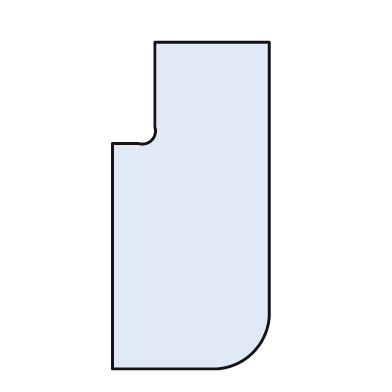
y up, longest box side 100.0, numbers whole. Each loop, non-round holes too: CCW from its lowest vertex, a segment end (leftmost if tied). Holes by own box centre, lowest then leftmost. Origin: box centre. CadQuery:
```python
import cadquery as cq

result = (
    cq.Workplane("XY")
    .moveTo(-24.0, -50.0)
    .lineTo(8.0, -50.0)
    .threePointArc((19.0, -45.0), (24.0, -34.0))
    .lineTo(24.0, 50.0)
    .lineTo(-11.0, 50.0)
    .lineTo(-11.0, 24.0)
    .threePointArc((-12.0, 20.0), (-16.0, 19.0))
    .lineTo(-24.0, 19.0)
    .close()
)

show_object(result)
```